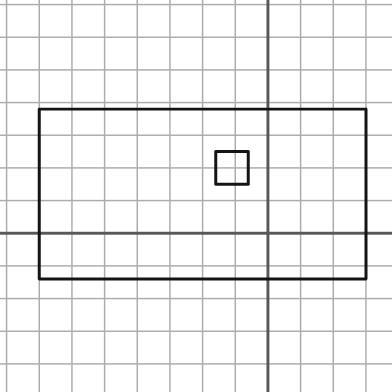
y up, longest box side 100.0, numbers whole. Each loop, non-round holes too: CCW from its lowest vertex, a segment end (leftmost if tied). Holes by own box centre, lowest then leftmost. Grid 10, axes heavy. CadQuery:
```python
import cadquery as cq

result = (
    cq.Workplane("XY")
    .moveTo(-70.0, -14.0)
    .lineTo(30.0, -14.0)
    .lineTo(30.0, 38.0)
    .lineTo(-70.0, 38.0)
    .close()
    .moveTo(-16.0, 15.0)
    .lineTo(-6.0, 15.0)
    .lineTo(-6.0, 25.0)
    .lineTo(-16.0, 25.0)
    .close()
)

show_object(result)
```